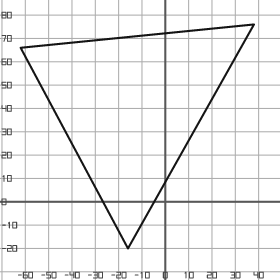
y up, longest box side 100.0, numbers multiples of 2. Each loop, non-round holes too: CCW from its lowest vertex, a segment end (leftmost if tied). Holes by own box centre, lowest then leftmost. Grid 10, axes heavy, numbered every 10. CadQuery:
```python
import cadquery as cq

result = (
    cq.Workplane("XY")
    .moveTo(-16.0, -20.0)
    .lineTo(38.0, 76.0)
    .lineTo(-62.0, 66.0)
    .close()
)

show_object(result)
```